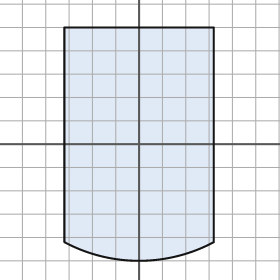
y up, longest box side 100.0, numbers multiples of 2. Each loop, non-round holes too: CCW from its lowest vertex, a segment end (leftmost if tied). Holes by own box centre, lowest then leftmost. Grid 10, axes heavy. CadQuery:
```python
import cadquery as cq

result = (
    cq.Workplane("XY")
    .moveTo(-32.0, -42.0)
    .threePointArc((0.0, -50.0), (32.0, -42.0))
    .lineTo(32.0, 50.0)
    .lineTo(-32.0, 50.0)
    .close()
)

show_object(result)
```